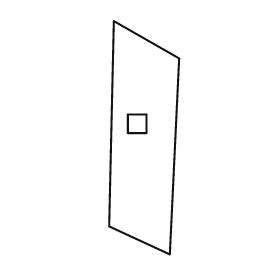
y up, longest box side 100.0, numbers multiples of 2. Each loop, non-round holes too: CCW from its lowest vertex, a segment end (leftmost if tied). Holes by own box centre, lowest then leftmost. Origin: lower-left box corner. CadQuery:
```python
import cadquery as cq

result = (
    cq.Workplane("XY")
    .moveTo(26.0, 0.0)
    .lineTo(30.0, 84.0)
    .lineTo(2.0, 100.0)
    .lineTo(0.0, 12.0)
    .close()
    .moveTo(8.0, 52.0)
    .lineTo(16.0, 52.0)
    .lineTo(16.0, 60.0)
    .lineTo(8.0, 60.0)
    .close()
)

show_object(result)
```